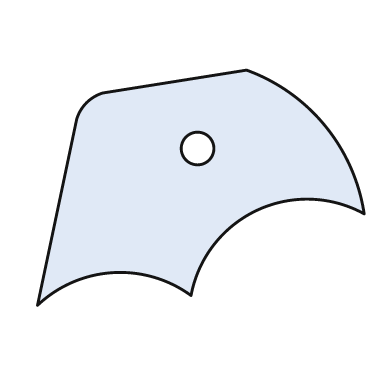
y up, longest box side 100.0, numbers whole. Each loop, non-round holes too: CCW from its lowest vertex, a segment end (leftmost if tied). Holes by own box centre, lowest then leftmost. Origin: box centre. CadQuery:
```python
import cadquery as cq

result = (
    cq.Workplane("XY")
    .moveTo(-50.0, -36.0)
    .threePointArc((-27.0, -26.0), (-3.0, -33.0))
    .threePointArc((17.0, -7.0), (50.0, -8.0))
    .threePointArc((38.0, 19.0), (14.0, 36.0))
    .lineTo(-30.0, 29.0)
    .threePointArc((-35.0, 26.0), (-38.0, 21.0))
    .close()
    .moveTo(-1.0, 12.0)
    .circle(5.0)
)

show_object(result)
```